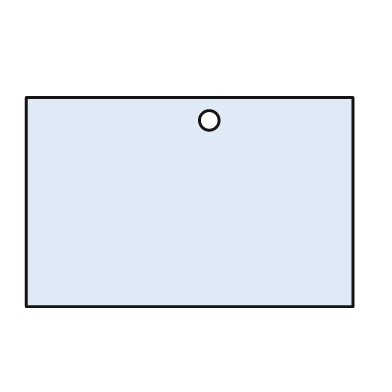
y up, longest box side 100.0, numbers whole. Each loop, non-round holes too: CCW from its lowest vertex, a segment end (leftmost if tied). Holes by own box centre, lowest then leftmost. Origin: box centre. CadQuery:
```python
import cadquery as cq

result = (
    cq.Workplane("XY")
    .moveTo(-50.0, -32.0)
    .lineTo(50.0, -32.0)
    .lineTo(50.0, 32.0)
    .lineTo(-50.0, 32.0)
    .close()
    .moveTo(6.0, 25.0)
    .circle(3.0)
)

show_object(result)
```